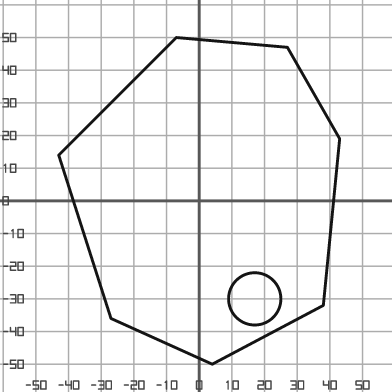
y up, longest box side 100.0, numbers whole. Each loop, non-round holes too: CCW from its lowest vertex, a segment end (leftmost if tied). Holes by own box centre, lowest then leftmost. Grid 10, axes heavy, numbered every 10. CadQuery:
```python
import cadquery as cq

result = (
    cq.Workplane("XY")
    .moveTo(4.0, -50.0)
    .lineTo(38.0, -32.0)
    .lineTo(43.0, 19.0)
    .lineTo(27.0, 47.0)
    .lineTo(-7.0, 50.0)
    .lineTo(-43.0, 14.0)
    .lineTo(-27.0, -36.0)
    .close()
    .moveTo(17.0, -30.0)
    .circle(8.0)
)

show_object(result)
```